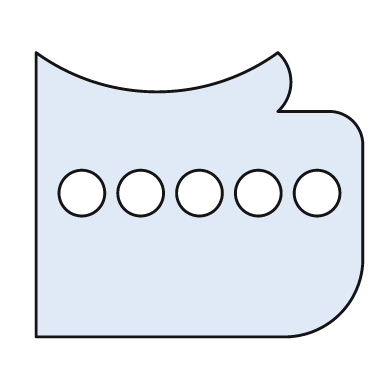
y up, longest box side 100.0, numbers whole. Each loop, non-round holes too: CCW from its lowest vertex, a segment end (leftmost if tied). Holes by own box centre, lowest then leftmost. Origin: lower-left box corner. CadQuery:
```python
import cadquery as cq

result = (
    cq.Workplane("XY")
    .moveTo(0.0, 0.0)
    .lineTo(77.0, 0.0)
    .threePointArc((93.0, 7.0), (100.0, 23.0))
    .lineTo(100.0, 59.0)
    .threePointArc((97.0, 66.0), (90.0, 69.0))
    .lineTo(74.0, 69.0)
    .threePointArc((78.0, 78.0), (74.0, 87.0))
    .threePointArc((37.0, 75.0), (0.0, 87.0))
    .close()
    .moveTo(14.0, 44.0)
    .circle(7.0)
    .moveTo(32.0, 44.0)
    .circle(7.0)
    .moveTo(50.0, 44.0)
    .circle(7.0)
    .moveTo(68.0, 44.0)
    .circle(7.0)
    .moveTo(86.0, 44.0)
    .circle(7.0)
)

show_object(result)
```